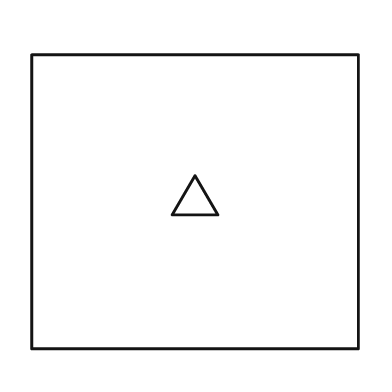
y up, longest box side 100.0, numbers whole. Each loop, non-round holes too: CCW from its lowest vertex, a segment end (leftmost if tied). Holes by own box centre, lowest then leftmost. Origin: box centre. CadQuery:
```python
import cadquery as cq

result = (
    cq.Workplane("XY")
    .moveTo(-50.0, -45.0)
    .lineTo(50.0, -45.0)
    .lineTo(50.0, 45.0)
    .lineTo(-50.0, 45.0)
    .close()
    .moveTo(-7.0, -4.0)
    .lineTo(7.0, -4.0)
    .lineTo(0.0, 8.0)
    .close()
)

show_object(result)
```